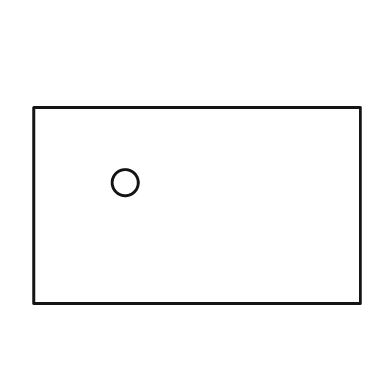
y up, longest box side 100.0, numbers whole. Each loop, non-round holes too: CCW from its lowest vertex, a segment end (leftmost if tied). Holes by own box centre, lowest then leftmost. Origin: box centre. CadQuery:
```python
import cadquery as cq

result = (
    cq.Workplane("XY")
    .moveTo(-50.0, -30.0)
    .lineTo(50.0, -30.0)
    .lineTo(50.0, 30.0)
    .lineTo(-50.0, 30.0)
    .close()
    .moveTo(-22.0, 7.0)
    .circle(4.0)
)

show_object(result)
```